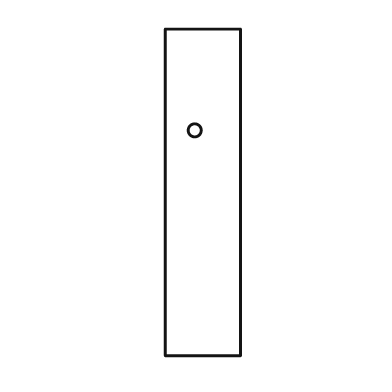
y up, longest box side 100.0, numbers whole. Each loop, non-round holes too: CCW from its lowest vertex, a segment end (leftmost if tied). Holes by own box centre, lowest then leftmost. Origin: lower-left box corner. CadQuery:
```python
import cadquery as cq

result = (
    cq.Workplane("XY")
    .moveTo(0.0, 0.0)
    .lineTo(23.0, 0.0)
    .lineTo(23.0, 100.0)
    .lineTo(0.0, 100.0)
    .close()
    .moveTo(9.0, 69.0)
    .circle(2.0)
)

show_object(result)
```